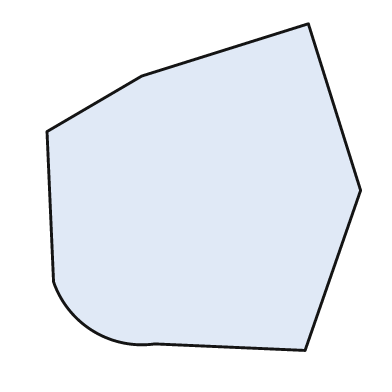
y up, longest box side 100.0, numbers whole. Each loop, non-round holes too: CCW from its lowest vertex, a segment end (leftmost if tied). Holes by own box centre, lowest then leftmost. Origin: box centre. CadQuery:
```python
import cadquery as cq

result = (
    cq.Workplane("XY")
    .moveTo(31.0, -50.0)
    .lineTo(48.0, -1.0)
    .lineTo(32.0, 50.0)
    .lineTo(-19.0, 34.0)
    .lineTo(-48.0, 17.0)
    .lineTo(-46.0, -29.0)
    .threePointArc((-34.0, -44.0), (-15.0, -48.0))
    .close()
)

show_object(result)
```